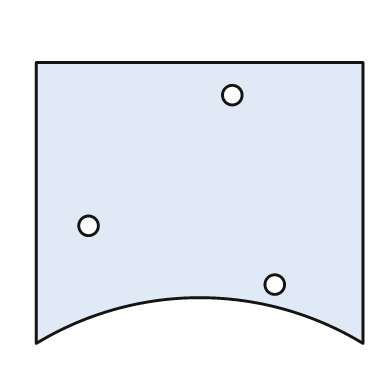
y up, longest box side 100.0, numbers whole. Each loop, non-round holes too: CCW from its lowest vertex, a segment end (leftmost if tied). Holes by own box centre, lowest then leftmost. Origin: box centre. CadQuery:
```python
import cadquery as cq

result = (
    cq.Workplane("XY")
    .moveTo(-50.0, -43.0)
    .threePointArc((0.0, -29.0), (50.0, -43.0))
    .lineTo(50.0, 43.0)
    .lineTo(-50.0, 43.0)
    .close()
    .moveTo(23.0, -25.0)
    .circle(3.0)
    .moveTo(-34.0, -7.0)
    .circle(3.0)
    .moveTo(10.0, 33.0)
    .circle(3.0)
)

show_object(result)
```